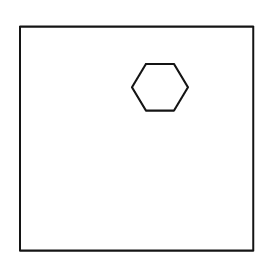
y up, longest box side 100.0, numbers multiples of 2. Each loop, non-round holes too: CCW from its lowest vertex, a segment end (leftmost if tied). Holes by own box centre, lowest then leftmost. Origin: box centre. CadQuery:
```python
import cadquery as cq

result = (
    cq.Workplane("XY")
    .moveTo(-50.0, -48.0)
    .lineTo(50.0, -48.0)
    .lineTo(50.0, 48.0)
    .lineTo(-50.0, 48.0)
    .close()
    .moveTo(4.0, 12.0)
    .lineTo(16.0, 12.0)
    .lineTo(22.0, 22.0)
    .lineTo(16.0, 32.0)
    .lineTo(4.0, 32.0)
    .lineTo(-2.0, 22.0)
    .close()
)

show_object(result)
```